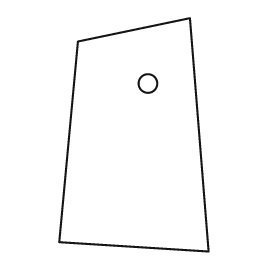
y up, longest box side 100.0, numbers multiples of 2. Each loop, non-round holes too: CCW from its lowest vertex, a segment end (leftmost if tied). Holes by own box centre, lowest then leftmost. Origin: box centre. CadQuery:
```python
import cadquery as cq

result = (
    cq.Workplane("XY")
    .moveTo(32.0, -50.0)
    .lineTo(24.0, 50.0)
    .lineTo(-24.0, 40.0)
    .lineTo(-32.0, -46.0)
    .close()
    .moveTo(6.0, 22.0)
    .circle(4.0)
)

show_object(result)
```